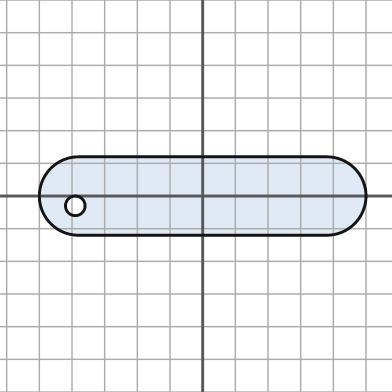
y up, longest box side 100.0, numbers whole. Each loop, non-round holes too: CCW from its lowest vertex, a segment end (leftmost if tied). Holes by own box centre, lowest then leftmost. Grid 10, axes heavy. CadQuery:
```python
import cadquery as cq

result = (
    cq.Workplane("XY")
    .moveTo(-38.0, -12.0)
    .lineTo(38.0, -12.0)
    .threePointArc((50.0, 0.0), (38.0, 12.0))
    .lineTo(-38.0, 12.0)
    .threePointArc((-50.0, 0.0), (-38.0, -12.0))
    .close()
    .moveTo(-39.0, -3.0)
    .circle(3.0)
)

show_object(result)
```